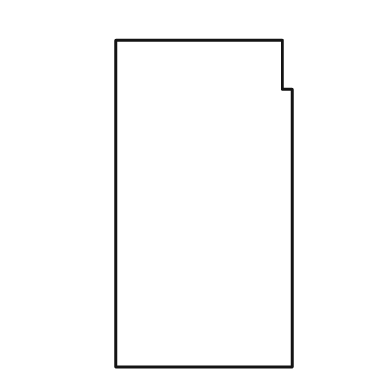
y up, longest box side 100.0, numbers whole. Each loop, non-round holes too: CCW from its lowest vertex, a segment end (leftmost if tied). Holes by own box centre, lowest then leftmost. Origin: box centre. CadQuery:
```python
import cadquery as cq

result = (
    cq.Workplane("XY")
    .moveTo(-27.0, -50.0)
    .lineTo(27.0, -50.0)
    .lineTo(27.0, 35.0)
    .lineTo(24.0, 35.0)
    .lineTo(24.0, 50.0)
    .lineTo(-27.0, 50.0)
    .close()
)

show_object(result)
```